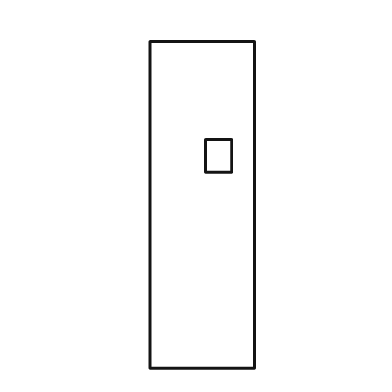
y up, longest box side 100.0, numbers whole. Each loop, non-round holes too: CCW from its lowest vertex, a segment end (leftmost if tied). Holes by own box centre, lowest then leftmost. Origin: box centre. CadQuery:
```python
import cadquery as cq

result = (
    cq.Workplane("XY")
    .moveTo(-16.0, -50.0)
    .lineTo(16.0, -50.0)
    .lineTo(16.0, 50.0)
    .lineTo(-16.0, 50.0)
    .close()
    .moveTo(1.0, 10.0)
    .lineTo(9.0, 10.0)
    .lineTo(9.0, 20.0)
    .lineTo(1.0, 20.0)
    .close()
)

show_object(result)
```